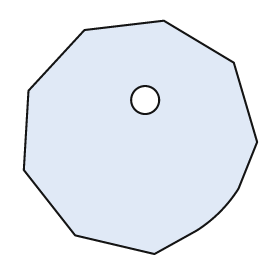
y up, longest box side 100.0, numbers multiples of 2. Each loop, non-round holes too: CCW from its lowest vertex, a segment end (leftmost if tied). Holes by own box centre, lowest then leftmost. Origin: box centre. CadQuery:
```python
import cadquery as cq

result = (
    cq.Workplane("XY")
    .moveTo(6.0, -50.0)
    .lineTo(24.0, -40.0)
    .threePointArc((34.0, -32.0), (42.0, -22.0))
    .lineTo(50.0, -2.0)
    .lineTo(40.0, 32.0)
    .lineTo(10.0, 50.0)
    .lineTo(-24.0, 46.0)
    .lineTo(-48.0, 20.0)
    .lineTo(-50.0, -14.0)
    .lineTo(-28.0, -42.0)
    .close()
    .moveTo(2.0, 16.0)
    .circle(6.0)
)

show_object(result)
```